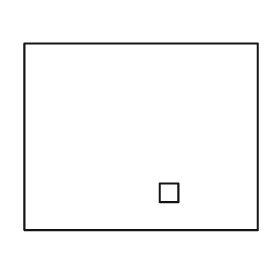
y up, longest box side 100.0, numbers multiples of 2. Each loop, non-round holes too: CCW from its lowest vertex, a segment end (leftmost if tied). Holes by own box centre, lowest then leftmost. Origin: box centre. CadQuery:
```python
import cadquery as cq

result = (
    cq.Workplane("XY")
    .moveTo(-50.0, -40.0)
    .lineTo(50.0, -40.0)
    .lineTo(50.0, 40.0)
    .lineTo(-50.0, 40.0)
    .close()
    .moveTo(8.0, -28.0)
    .lineTo(16.0, -28.0)
    .lineTo(16.0, -20.0)
    .lineTo(8.0, -20.0)
    .close()
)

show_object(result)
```